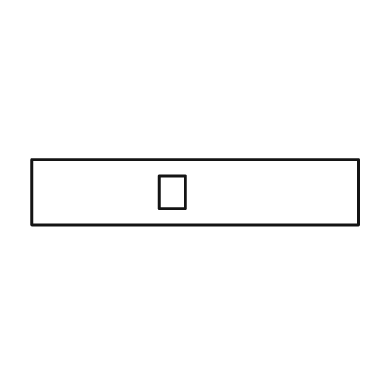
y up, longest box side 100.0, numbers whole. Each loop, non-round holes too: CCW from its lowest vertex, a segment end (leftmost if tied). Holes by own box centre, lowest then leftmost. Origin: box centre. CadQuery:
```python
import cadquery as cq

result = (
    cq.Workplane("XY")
    .moveTo(-50.0, -10.0)
    .lineTo(50.0, -10.0)
    .lineTo(50.0, 10.0)
    .lineTo(-50.0, 10.0)
    .close()
    .moveTo(-11.0, -5.0)
    .lineTo(-3.0, -5.0)
    .lineTo(-3.0, 5.0)
    .lineTo(-11.0, 5.0)
    .close()
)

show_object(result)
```